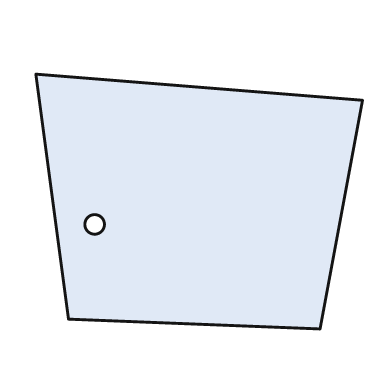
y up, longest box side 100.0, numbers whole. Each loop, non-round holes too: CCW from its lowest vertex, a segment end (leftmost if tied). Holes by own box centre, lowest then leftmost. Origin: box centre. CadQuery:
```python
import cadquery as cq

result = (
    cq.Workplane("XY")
    .moveTo(37.0, -39.0)
    .lineTo(50.0, 31.0)
    .lineTo(-50.0, 39.0)
    .lineTo(-40.0, -36.0)
    .close()
    .moveTo(-32.0, -7.0)
    .circle(3.0)
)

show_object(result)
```